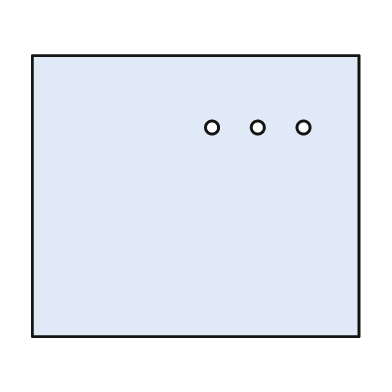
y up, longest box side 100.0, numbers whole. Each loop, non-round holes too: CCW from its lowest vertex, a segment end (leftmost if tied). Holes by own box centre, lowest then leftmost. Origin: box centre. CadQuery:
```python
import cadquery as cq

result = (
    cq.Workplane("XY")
    .moveTo(-50.0, -43.0)
    .lineTo(50.0, -43.0)
    .lineTo(50.0, 43.0)
    .lineTo(-50.0, 43.0)
    .close()
    .moveTo(5.0, 21.0)
    .circle(2.0)
    .moveTo(19.0, 21.0)
    .circle(2.0)
    .moveTo(33.0, 21.0)
    .circle(2.0)
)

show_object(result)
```